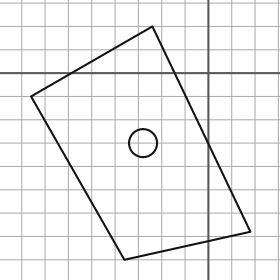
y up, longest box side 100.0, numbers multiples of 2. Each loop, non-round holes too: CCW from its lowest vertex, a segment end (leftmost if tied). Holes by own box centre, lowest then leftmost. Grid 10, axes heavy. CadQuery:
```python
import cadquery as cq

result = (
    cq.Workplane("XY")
    .moveTo(-36.0, -80.0)
    .lineTo(18.0, -68.0)
    .lineTo(-24.0, 20.0)
    .lineTo(-76.0, -10.0)
    .close()
    .moveTo(-28.0, -30.0)
    .circle(6.0)
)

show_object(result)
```